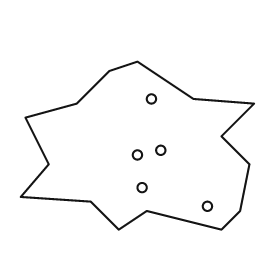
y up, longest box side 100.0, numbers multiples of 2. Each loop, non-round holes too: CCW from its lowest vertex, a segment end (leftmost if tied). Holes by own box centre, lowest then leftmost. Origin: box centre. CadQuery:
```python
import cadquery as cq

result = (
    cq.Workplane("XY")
    .moveTo(-8.0, -36.0)
    .lineTo(4.0, -28.0)
    .lineTo(36.0, -36.0)
    .lineTo(44.0, -28.0)
    .lineTo(48.0, -8.0)
    .lineTo(36.0, 4.0)
    .lineTo(50.0, 18.0)
    .lineTo(24.0, 20.0)
    .lineTo(0.0, 36.0)
    .lineTo(-12.0, 32.0)
    .lineTo(-26.0, 18.0)
    .lineTo(-48.0, 12.0)
    .lineTo(-38.0, -8.0)
    .lineTo(-50.0, -22.0)
    .lineTo(-20.0, -24.0)
    .close()
    .moveTo(30.0, -26.0)
    .circle(2.0)
    .moveTo(2.0, -18.0)
    .circle(2.0)
    .moveTo(0.0, -4.0)
    .circle(2.0)
    .moveTo(10.0, -2.0)
    .circle(2.0)
    .moveTo(6.0, 20.0)
    .circle(2.0)
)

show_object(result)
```